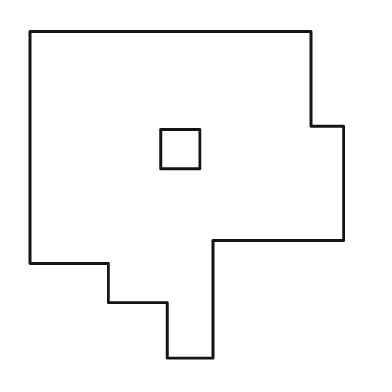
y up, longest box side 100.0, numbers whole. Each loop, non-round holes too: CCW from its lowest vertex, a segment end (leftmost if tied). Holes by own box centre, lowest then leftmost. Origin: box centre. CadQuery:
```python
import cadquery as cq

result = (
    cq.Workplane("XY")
    .moveTo(-6.0, -50.0)
    .lineTo(8.0, -50.0)
    .lineTo(8.0, -14.0)
    .lineTo(48.0, -14.0)
    .lineTo(48.0, 21.0)
    .lineTo(38.0, 21.0)
    .lineTo(38.0, 50.0)
    .lineTo(-48.0, 50.0)
    .lineTo(-48.0, -21.0)
    .lineTo(-24.0, -21.0)
    .lineTo(-24.0, -33.0)
    .lineTo(-6.0, -33.0)
    .close()
    .moveTo(-8.0, 8.0)
    .lineTo(4.0, 8.0)
    .lineTo(4.0, 20.0)
    .lineTo(-8.0, 20.0)
    .close()
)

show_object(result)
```